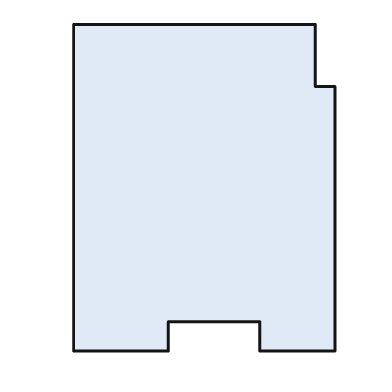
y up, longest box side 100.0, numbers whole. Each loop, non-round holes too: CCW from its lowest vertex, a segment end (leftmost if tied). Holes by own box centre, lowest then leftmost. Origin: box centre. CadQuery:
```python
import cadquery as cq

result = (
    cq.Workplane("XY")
    .moveTo(-40.0, -50.0)
    .lineTo(-11.0, -50.0)
    .lineTo(-11.0, -41.0)
    .lineTo(17.0, -41.0)
    .lineTo(17.0, -50.0)
    .lineTo(40.0, -50.0)
    .lineTo(40.0, 31.0)
    .lineTo(34.0, 31.0)
    .lineTo(34.0, 50.0)
    .lineTo(-40.0, 50.0)
    .close()
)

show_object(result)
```